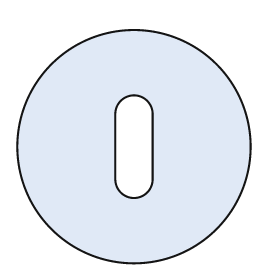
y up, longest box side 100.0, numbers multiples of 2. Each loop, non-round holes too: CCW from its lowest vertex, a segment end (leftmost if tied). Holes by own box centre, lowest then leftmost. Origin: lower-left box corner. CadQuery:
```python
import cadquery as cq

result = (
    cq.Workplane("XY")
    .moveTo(50.0, 50.0)
    .circle(50.0)
    .moveTo(42.0, 36.0)
    .threePointArc((50.0, 28.0), (58.0, 36.0))
    .lineTo(58.0, 64.0)
    .threePointArc((50.0, 72.0), (42.0, 64.0))
    .close()
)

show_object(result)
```